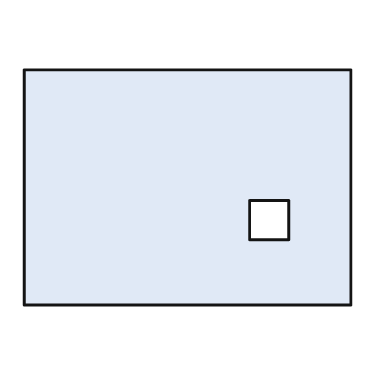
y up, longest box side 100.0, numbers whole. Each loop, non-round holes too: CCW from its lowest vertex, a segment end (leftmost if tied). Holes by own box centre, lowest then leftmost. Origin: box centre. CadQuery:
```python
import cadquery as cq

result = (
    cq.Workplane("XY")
    .moveTo(-50.0, -36.0)
    .lineTo(50.0, -36.0)
    .lineTo(50.0, 36.0)
    .lineTo(-50.0, 36.0)
    .close()
    .moveTo(19.0, -16.0)
    .lineTo(31.0, -16.0)
    .lineTo(31.0, -4.0)
    .lineTo(19.0, -4.0)
    .close()
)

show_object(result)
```